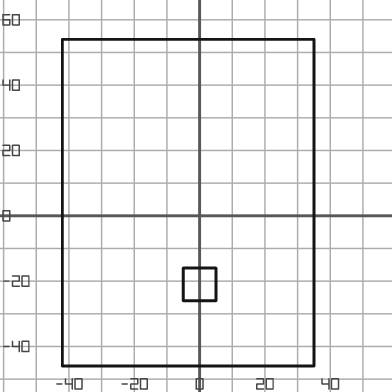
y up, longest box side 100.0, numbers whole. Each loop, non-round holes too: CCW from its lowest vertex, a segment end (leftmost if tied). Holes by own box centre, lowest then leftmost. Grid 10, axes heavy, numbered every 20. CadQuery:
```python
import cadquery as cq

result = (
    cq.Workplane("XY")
    .moveTo(-42.0, -46.0)
    .lineTo(35.0, -46.0)
    .lineTo(35.0, 54.0)
    .lineTo(-42.0, 54.0)
    .close()
    .moveTo(-5.0, -26.0)
    .lineTo(5.0, -26.0)
    .lineTo(5.0, -16.0)
    .lineTo(-5.0, -16.0)
    .close()
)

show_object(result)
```